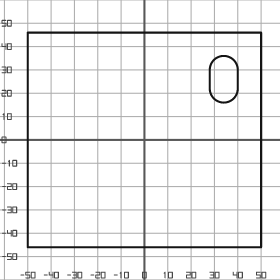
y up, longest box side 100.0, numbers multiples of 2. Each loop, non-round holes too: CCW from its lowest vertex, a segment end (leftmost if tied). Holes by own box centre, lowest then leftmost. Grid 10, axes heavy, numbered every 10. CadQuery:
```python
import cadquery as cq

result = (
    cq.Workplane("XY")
    .moveTo(-50.0, -46.0)
    .lineTo(50.0, -46.0)
    .lineTo(50.0, 46.0)
    .lineTo(-50.0, 46.0)
    .close()
    .moveTo(28.0, 22.0)
    .threePointArc((34.0, 16.0), (40.0, 22.0))
    .lineTo(40.0, 30.0)
    .threePointArc((34.0, 36.0), (28.0, 30.0))
    .close()
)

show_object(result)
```